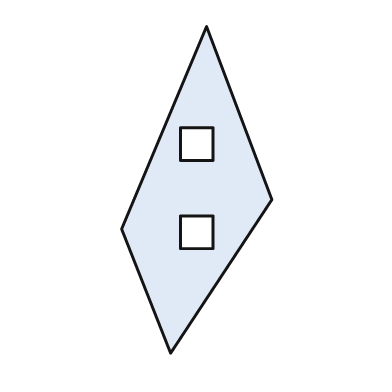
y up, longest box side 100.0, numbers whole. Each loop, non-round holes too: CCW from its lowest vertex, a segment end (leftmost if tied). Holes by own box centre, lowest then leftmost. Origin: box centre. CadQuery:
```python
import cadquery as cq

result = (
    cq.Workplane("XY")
    .moveTo(-8.0, -50.0)
    .lineTo(23.0, -3.0)
    .lineTo(3.0, 50.0)
    .lineTo(-23.0, -12.0)
    .close()
    .moveTo(-5.0, -18.0)
    .lineTo(5.0, -18.0)
    .lineTo(5.0, -8.0)
    .lineTo(-5.0, -8.0)
    .close()
    .moveTo(-5.0, 9.0)
    .lineTo(5.0, 9.0)
    .lineTo(5.0, 19.0)
    .lineTo(-5.0, 19.0)
    .close()
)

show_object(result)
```